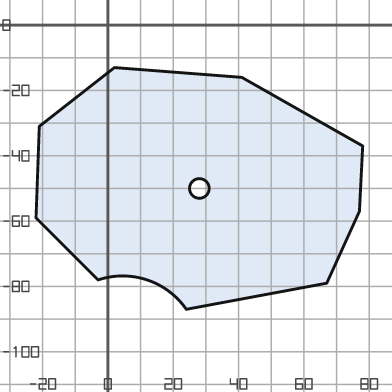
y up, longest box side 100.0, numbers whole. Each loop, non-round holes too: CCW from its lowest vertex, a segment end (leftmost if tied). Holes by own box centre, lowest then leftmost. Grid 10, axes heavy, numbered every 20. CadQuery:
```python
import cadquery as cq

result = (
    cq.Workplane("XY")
    .moveTo(24.0, -87.0)
    .lineTo(67.0, -79.0)
    .lineTo(77.0, -57.0)
    .lineTo(78.0, -37.0)
    .lineTo(41.0, -16.0)
    .lineTo(2.0, -13.0)
    .lineTo(-21.0, -31.0)
    .lineTo(-22.0, -59.0)
    .lineTo(-3.0, -78.0)
    .threePointArc((12.0, -78.0), (24.0, -87.0))
    .close()
    .moveTo(28.0, -50.0)
    .circle(3.0)
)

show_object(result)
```